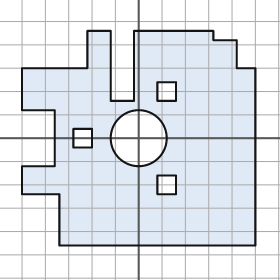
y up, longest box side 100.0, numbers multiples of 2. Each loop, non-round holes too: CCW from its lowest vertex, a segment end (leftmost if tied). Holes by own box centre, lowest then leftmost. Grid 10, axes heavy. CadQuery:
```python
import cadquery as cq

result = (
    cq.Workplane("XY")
    .moveTo(-34.0, -46.0)
    .lineTo(50.0, -46.0)
    .lineTo(50.0, 30.0)
    .lineTo(42.0, 30.0)
    .lineTo(42.0, 42.0)
    .lineTo(32.0, 42.0)
    .lineTo(32.0, 46.0)
    .lineTo(-2.0, 46.0)
    .lineTo(-2.0, 16.0)
    .lineTo(-12.0, 16.0)
    .lineTo(-12.0, 46.0)
    .lineTo(-22.0, 46.0)
    .lineTo(-22.0, 30.0)
    .lineTo(-50.0, 30.0)
    .lineTo(-50.0, 12.0)
    .lineTo(-36.0, 12.0)
    .lineTo(-36.0, -12.0)
    .lineTo(-50.0, -12.0)
    .lineTo(-50.0, -24.0)
    .lineTo(-34.0, -24.0)
    .close()
    .moveTo(8.0, -24.0)
    .lineTo(16.0, -24.0)
    .lineTo(16.0, -16.0)
    .lineTo(8.0, -16.0)
    .close()
    .moveTo(-28.0, -4.0)
    .lineTo(-20.0, -4.0)
    .lineTo(-20.0, 4.0)
    .lineTo(-28.0, 4.0)
    .close()
    .moveTo(0.0, 0.0)
    .circle(12.0)
    .moveTo(8.0, 16.0)
    .lineTo(16.0, 16.0)
    .lineTo(16.0, 24.0)
    .lineTo(8.0, 24.0)
    .close()
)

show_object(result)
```